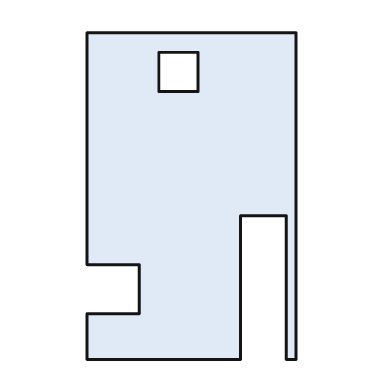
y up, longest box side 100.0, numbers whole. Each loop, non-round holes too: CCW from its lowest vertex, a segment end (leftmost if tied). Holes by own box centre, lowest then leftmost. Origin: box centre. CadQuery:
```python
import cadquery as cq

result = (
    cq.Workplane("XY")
    .moveTo(-32.0, -50.0)
    .lineTo(15.0, -50.0)
    .lineTo(15.0, -6.0)
    .lineTo(29.0, -6.0)
    .lineTo(29.0, -50.0)
    .lineTo(32.0, -50.0)
    .lineTo(32.0, 50.0)
    .lineTo(-32.0, 50.0)
    .lineTo(-32.0, -21.0)
    .lineTo(-16.0, -21.0)
    .lineTo(-16.0, -36.0)
    .lineTo(-32.0, -36.0)
    .close()
    .moveTo(-10.0, 32.0)
    .lineTo(2.0, 32.0)
    .lineTo(2.0, 44.0)
    .lineTo(-10.0, 44.0)
    .close()
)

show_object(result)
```